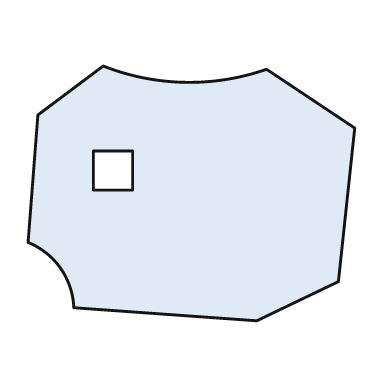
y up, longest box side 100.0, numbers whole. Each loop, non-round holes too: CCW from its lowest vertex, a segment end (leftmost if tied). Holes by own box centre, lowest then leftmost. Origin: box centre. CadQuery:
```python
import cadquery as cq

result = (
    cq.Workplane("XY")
    .moveTo(20.0, -39.0)
    .lineTo(45.0, -27.0)
    .lineTo(50.0, 20.0)
    .lineTo(23.0, 38.0)
    .threePointArc((-2.0, 34.0), (-27.0, 39.0))
    .lineTo(-47.0, 24.0)
    .lineTo(-50.0, -15.0)
    .threePointArc((-40.0, -23.0), (-36.0, -35.0))
    .close()
    .moveTo(-30.0, 1.0)
    .lineTo(-18.0, 1.0)
    .lineTo(-18.0, 13.0)
    .lineTo(-30.0, 13.0)
    .close()
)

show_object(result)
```